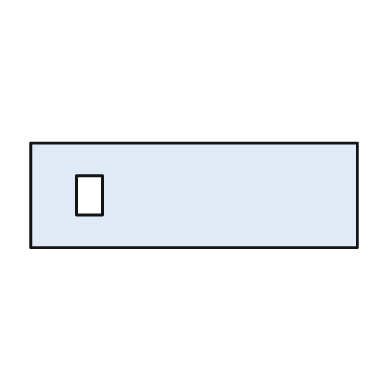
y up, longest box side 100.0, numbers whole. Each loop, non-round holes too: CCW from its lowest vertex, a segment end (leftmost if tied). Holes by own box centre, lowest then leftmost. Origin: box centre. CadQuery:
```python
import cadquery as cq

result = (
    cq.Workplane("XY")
    .moveTo(-50.0, -16.0)
    .lineTo(50.0, -16.0)
    .lineTo(50.0, 16.0)
    .lineTo(-50.0, 16.0)
    .close()
    .moveTo(-36.0, -6.0)
    .lineTo(-28.0, -6.0)
    .lineTo(-28.0, 6.0)
    .lineTo(-36.0, 6.0)
    .close()
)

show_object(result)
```